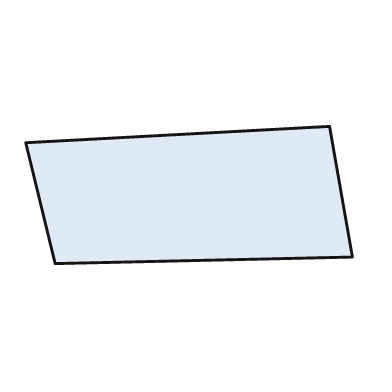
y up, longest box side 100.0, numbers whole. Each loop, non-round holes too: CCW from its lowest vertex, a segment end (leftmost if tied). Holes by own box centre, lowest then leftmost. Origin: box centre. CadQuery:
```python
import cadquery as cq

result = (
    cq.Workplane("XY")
    .moveTo(-41.0, -21.0)
    .lineTo(50.0, -19.0)
    .lineTo(43.0, 21.0)
    .lineTo(-50.0, 16.0)
    .close()
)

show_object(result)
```